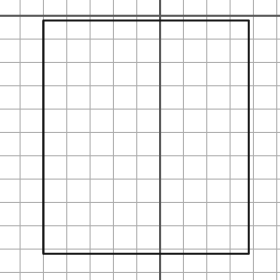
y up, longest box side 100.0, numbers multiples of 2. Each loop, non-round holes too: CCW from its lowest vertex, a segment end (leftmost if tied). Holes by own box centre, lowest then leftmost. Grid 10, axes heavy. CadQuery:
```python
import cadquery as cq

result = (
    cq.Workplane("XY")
    .moveTo(-50.0, -102.0)
    .lineTo(38.0, -102.0)
    .lineTo(38.0, -2.0)
    .lineTo(-50.0, -2.0)
    .close()
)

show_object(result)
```